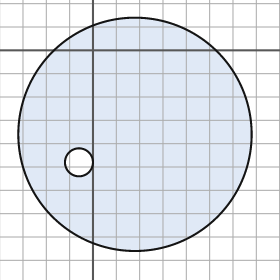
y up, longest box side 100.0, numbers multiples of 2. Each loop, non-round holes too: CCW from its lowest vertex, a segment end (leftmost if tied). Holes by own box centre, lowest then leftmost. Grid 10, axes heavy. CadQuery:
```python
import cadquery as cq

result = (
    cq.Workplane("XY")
    .moveTo(18.0, -36.0)
    .circle(50.0)
    .moveTo(-6.0, -48.0)
    .circle(6.0)
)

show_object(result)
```